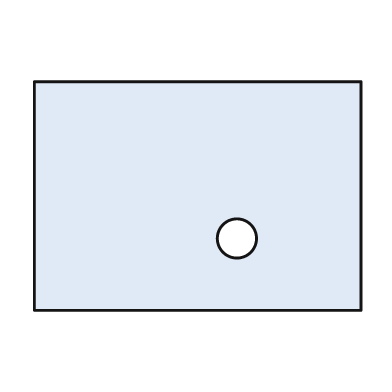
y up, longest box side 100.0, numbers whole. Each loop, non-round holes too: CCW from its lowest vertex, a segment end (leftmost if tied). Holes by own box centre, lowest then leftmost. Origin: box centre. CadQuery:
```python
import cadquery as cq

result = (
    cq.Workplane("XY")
    .moveTo(-50.0, -35.0)
    .lineTo(50.0, -35.0)
    .lineTo(50.0, 35.0)
    .lineTo(-50.0, 35.0)
    .close()
    .moveTo(12.0, -13.0)
    .circle(6.0)
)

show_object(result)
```